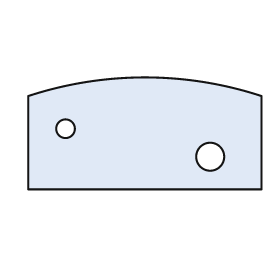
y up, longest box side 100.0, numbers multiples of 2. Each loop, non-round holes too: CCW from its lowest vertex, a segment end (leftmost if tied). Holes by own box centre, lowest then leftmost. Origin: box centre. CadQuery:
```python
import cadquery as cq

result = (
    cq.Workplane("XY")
    .moveTo(-50.0, -24.0)
    .lineTo(50.0, -24.0)
    .lineTo(50.0, 16.0)
    .threePointArc((0.0, 24.0), (-50.0, 16.0))
    .close()
    .moveTo(28.0, -10.0)
    .circle(6.0)
    .moveTo(-34.0, 2.0)
    .circle(4.0)
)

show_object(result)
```